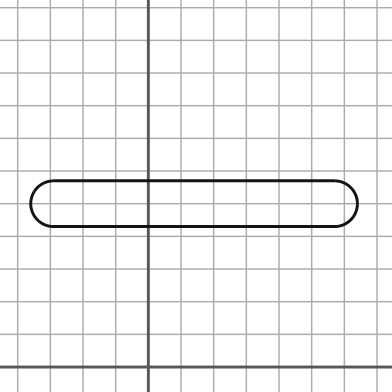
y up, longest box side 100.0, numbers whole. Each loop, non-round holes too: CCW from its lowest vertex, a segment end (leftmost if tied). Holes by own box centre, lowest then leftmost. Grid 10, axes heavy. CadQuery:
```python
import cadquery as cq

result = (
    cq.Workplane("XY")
    .moveTo(-29.0, 43.0)
    .lineTo(57.0, 43.0)
    .threePointArc((64.0, 50.0), (57.0, 57.0))
    .lineTo(-29.0, 57.0)
    .threePointArc((-36.0, 50.0), (-29.0, 43.0))
    .close()
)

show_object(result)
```